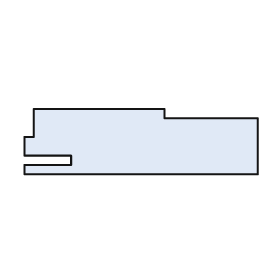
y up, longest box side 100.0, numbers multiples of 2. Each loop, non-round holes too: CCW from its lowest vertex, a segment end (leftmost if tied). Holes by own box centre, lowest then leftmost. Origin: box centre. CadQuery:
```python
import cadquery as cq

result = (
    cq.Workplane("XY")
    .moveTo(-50.0, -14.0)
    .lineTo(50.0, -14.0)
    .lineTo(50.0, 10.0)
    .lineTo(10.0, 10.0)
    .lineTo(10.0, 14.0)
    .lineTo(-46.0, 14.0)
    .lineTo(-46.0, 2.0)
    .lineTo(-50.0, 2.0)
    .lineTo(-50.0, -6.0)
    .lineTo(-30.0, -6.0)
    .lineTo(-30.0, -10.0)
    .lineTo(-50.0, -10.0)
    .close()
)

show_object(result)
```